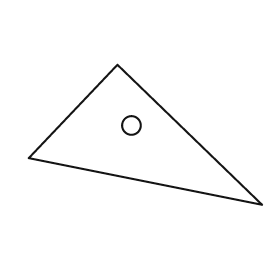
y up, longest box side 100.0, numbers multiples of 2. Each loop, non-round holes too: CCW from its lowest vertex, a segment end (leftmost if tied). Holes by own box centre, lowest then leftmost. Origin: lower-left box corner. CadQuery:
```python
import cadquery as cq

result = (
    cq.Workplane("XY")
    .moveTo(100.0, 0.0)
    .lineTo(38.0, 60.0)
    .lineTo(0.0, 20.0)
    .close()
    .moveTo(44.0, 34.0)
    .circle(4.0)
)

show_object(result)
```